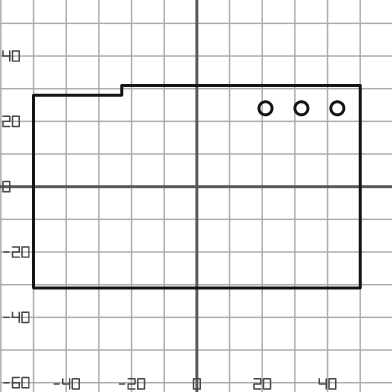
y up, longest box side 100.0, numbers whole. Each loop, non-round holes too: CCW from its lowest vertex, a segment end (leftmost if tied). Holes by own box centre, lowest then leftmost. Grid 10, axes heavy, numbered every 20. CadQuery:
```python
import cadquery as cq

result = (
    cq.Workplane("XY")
    .moveTo(-50.0, -31.0)
    .lineTo(50.0, -31.0)
    .lineTo(50.0, 31.0)
    .lineTo(-23.0, 31.0)
    .lineTo(-23.0, 28.0)
    .lineTo(-50.0, 28.0)
    .close()
    .moveTo(21.0, 24.0)
    .circle(2.0)
    .moveTo(32.0, 24.0)
    .circle(2.0)
    .moveTo(43.0, 24.0)
    .circle(2.0)
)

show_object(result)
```